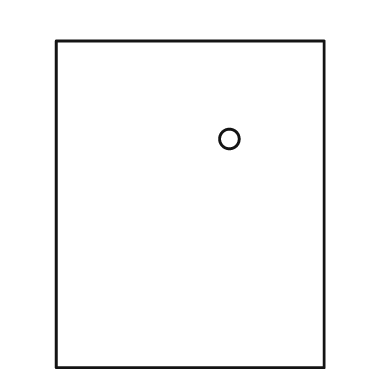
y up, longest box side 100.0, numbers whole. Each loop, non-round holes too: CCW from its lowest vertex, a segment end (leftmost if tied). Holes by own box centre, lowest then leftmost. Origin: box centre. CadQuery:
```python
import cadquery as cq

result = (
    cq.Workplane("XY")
    .moveTo(-41.0, -50.0)
    .lineTo(41.0, -50.0)
    .lineTo(41.0, 50.0)
    .lineTo(-41.0, 50.0)
    .close()
    .moveTo(12.0, 20.0)
    .circle(3.0)
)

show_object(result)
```